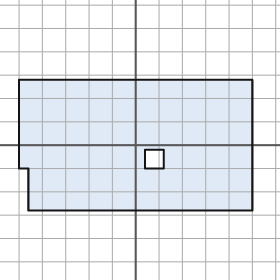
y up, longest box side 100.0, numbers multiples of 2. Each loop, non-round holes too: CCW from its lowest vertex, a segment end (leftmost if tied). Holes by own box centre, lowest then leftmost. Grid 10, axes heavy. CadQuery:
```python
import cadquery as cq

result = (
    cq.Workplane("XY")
    .moveTo(-46.0, -28.0)
    .lineTo(50.0, -28.0)
    .lineTo(50.0, 28.0)
    .lineTo(-50.0, 28.0)
    .lineTo(-50.0, -10.0)
    .lineTo(-46.0, -10.0)
    .close()
    .moveTo(4.0, -10.0)
    .lineTo(12.0, -10.0)
    .lineTo(12.0, -2.0)
    .lineTo(4.0, -2.0)
    .close()
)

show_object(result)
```